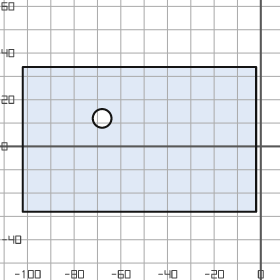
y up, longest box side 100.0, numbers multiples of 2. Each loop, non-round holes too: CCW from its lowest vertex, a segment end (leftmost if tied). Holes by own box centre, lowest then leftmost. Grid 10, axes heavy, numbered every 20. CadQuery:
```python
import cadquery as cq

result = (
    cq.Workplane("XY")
    .moveTo(-102.0, -28.0)
    .lineTo(-2.0, -28.0)
    .lineTo(-2.0, 34.0)
    .lineTo(-102.0, 34.0)
    .close()
    .moveTo(-68.0, 12.0)
    .circle(4.0)
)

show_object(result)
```